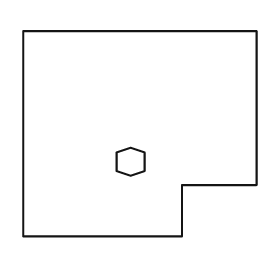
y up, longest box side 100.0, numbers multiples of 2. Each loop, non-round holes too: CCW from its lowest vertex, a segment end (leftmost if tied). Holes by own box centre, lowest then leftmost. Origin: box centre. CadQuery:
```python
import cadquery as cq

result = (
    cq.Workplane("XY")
    .moveTo(-50.0, -44.0)
    .lineTo(18.0, -44.0)
    .lineTo(18.0, -22.0)
    .lineTo(50.0, -22.0)
    .lineTo(50.0, 44.0)
    .lineTo(-50.0, 44.0)
    .close()
    .moveTo(-4.0, -18.0)
    .lineTo(2.0, -16.0)
    .lineTo(2.0, -8.0)
    .lineTo(-4.0, -6.0)
    .lineTo(-10.0, -8.0)
    .lineTo(-10.0, -16.0)
    .close()
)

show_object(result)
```